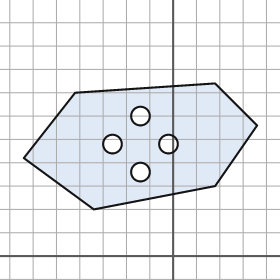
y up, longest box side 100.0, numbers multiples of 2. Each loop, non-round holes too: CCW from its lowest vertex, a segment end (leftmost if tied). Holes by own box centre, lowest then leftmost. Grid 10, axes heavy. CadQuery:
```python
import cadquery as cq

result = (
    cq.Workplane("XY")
    .moveTo(-34.0, 20.0)
    .lineTo(18.0, 30.0)
    .lineTo(36.0, 56.0)
    .lineTo(18.0, 74.0)
    .lineTo(-42.0, 70.0)
    .lineTo(-64.0, 42.0)
    .close()
    .moveTo(-14.0, 36.0)
    .circle(4.0)
    .moveTo(-26.0, 48.0)
    .circle(4.0)
    .moveTo(-2.0, 48.0)
    .circle(4.0)
    .moveTo(-14.0, 60.0)
    .circle(4.0)
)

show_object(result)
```